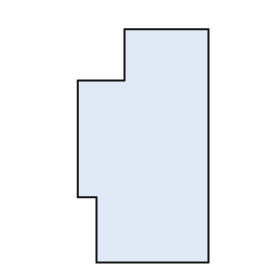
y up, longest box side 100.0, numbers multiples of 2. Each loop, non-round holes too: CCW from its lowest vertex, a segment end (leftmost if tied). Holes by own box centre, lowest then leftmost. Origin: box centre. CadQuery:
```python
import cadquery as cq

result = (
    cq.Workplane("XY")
    .moveTo(-20.0, -50.0)
    .lineTo(28.0, -50.0)
    .lineTo(28.0, 50.0)
    .lineTo(-8.0, 50.0)
    .lineTo(-8.0, 28.0)
    .lineTo(-28.0, 28.0)
    .lineTo(-28.0, -22.0)
    .lineTo(-20.0, -22.0)
    .close()
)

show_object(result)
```